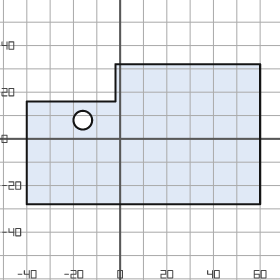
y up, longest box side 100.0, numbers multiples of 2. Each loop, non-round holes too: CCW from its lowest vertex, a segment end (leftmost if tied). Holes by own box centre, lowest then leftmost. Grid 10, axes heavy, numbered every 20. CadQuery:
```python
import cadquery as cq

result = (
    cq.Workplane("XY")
    .moveTo(-40.0, -28.0)
    .lineTo(60.0, -28.0)
    .lineTo(60.0, 32.0)
    .lineTo(-2.0, 32.0)
    .lineTo(-2.0, 16.0)
    .lineTo(-40.0, 16.0)
    .close()
    .moveTo(-16.0, 8.0)
    .circle(4.0)
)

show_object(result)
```